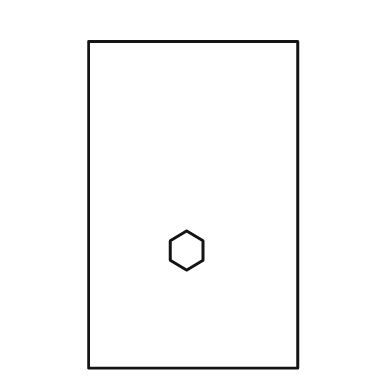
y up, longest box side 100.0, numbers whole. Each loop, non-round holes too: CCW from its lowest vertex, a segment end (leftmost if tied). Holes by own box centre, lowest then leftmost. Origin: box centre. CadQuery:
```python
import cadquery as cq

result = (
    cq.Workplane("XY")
    .moveTo(-32.0, -50.0)
    .lineTo(32.0, -50.0)
    .lineTo(32.0, 50.0)
    .lineTo(-32.0, 50.0)
    .close()
    .moveTo(-2.0, -20.0)
    .lineTo(3.0, -17.0)
    .lineTo(3.0, -11.0)
    .lineTo(-2.0, -8.0)
    .lineTo(-7.0, -11.0)
    .lineTo(-7.0, -17.0)
    .close()
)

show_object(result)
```